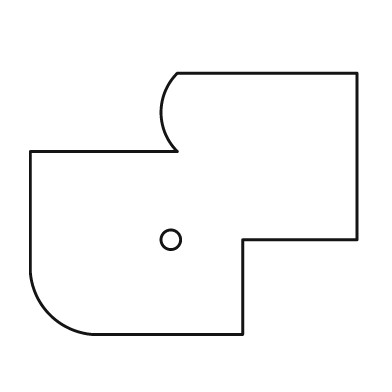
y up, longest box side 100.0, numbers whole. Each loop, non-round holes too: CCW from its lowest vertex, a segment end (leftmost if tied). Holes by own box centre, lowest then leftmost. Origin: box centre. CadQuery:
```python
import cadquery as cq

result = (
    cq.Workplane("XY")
    .moveTo(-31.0, -40.0)
    .lineTo(15.0, -40.0)
    .lineTo(15.0, -11.0)
    .lineTo(50.0, -11.0)
    .lineTo(50.0, 40.0)
    .lineTo(-5.0, 40.0)
    .threePointArc((-10.0, 28.0), (-5.0, 16.0))
    .lineTo(-50.0, 16.0)
    .lineTo(-50.0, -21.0)
    .threePointArc((-44.0, -34.0), (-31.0, -40.0))
    .close()
    .moveTo(-7.0, -11.0)
    .circle(3.0)
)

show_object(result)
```